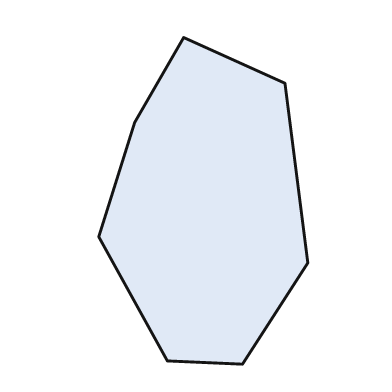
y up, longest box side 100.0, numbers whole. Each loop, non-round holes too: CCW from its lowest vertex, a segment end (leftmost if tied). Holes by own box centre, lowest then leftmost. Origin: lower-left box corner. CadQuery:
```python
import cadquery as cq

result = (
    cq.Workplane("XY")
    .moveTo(44.0, 0.0)
    .lineTo(64.0, 31.0)
    .lineTo(57.0, 86.0)
    .lineTo(26.0, 100.0)
    .lineTo(11.0, 74.0)
    .lineTo(0.0, 39.0)
    .lineTo(21.0, 1.0)
    .close()
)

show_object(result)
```